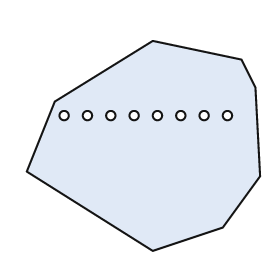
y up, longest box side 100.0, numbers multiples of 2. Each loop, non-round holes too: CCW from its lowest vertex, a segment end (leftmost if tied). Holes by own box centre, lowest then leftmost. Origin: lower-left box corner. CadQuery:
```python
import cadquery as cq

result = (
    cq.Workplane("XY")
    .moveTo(54.0, 0.0)
    .lineTo(84.0, 10.0)
    .lineTo(100.0, 32.0)
    .lineTo(98.0, 70.0)
    .lineTo(92.0, 82.0)
    .lineTo(54.0, 90.0)
    .lineTo(12.0, 64.0)
    .lineTo(0.0, 34.0)
    .close()
    .moveTo(16.0, 58.0)
    .circle(2.0)
    .moveTo(26.0, 58.0)
    .circle(2.0)
    .moveTo(36.0, 58.0)
    .circle(2.0)
    .moveTo(46.0, 58.0)
    .circle(2.0)
    .moveTo(56.0, 58.0)
    .circle(2.0)
    .moveTo(66.0, 58.0)
    .circle(2.0)
    .moveTo(76.0, 58.0)
    .circle(2.0)
    .moveTo(86.0, 58.0)
    .circle(2.0)
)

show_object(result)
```